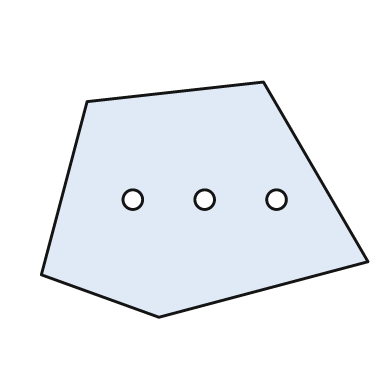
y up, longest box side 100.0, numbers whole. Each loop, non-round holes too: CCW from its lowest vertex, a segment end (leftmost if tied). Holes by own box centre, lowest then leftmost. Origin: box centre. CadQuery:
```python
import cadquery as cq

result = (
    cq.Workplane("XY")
    .moveTo(-14.0, -36.0)
    .lineTo(50.0, -19.0)
    .lineTo(18.0, 36.0)
    .lineTo(-36.0, 30.0)
    .lineTo(-50.0, -23.0)
    .close()
    .moveTo(-22.0, 0.0)
    .circle(3.0)
    .moveTo(0.0, 0.0)
    .circle(3.0)
    .moveTo(22.0, 0.0)
    .circle(3.0)
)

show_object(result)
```